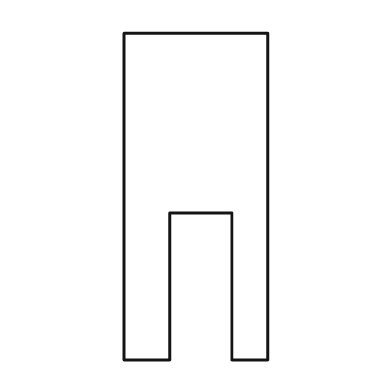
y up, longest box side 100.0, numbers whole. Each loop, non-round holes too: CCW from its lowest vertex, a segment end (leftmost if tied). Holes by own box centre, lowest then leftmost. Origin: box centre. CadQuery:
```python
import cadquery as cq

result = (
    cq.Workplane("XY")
    .moveTo(-22.0, -50.0)
    .lineTo(-8.0, -50.0)
    .lineTo(-8.0, -5.0)
    .lineTo(11.0, -5.0)
    .lineTo(11.0, -50.0)
    .lineTo(22.0, -50.0)
    .lineTo(22.0, 50.0)
    .lineTo(-22.0, 50.0)
    .close()
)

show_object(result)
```